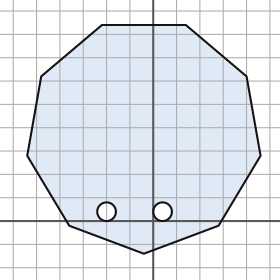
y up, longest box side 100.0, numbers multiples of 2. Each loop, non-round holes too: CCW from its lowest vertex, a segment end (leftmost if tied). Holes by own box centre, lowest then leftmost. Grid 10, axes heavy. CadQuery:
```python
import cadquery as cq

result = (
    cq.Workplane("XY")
    .moveTo(-4.0, -14.0)
    .lineTo(28.0, -2.0)
    .lineTo(46.0, 28.0)
    .lineTo(40.0, 62.0)
    .lineTo(14.0, 84.0)
    .lineTo(-22.0, 84.0)
    .lineTo(-48.0, 62.0)
    .lineTo(-54.0, 28.0)
    .lineTo(-36.0, -2.0)
    .close()
    .moveTo(-20.0, 4.0)
    .circle(4.0)
    .moveTo(4.0, 4.0)
    .circle(4.0)
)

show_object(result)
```